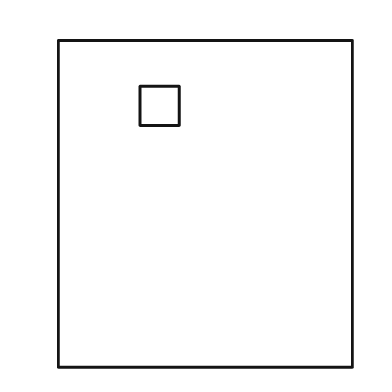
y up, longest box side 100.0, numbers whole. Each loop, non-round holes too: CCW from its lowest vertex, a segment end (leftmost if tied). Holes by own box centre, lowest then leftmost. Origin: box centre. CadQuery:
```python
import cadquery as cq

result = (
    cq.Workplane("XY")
    .moveTo(-45.0, -50.0)
    .lineTo(45.0, -50.0)
    .lineTo(45.0, 50.0)
    .lineTo(-45.0, 50.0)
    .close()
    .moveTo(-20.0, 24.0)
    .lineTo(-8.0, 24.0)
    .lineTo(-8.0, 36.0)
    .lineTo(-20.0, 36.0)
    .close()
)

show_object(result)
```